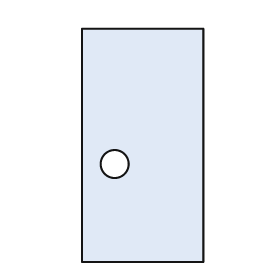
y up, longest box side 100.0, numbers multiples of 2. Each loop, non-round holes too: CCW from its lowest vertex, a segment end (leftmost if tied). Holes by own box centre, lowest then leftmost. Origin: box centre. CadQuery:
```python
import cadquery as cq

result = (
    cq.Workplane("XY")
    .moveTo(-26.0, -50.0)
    .lineTo(26.0, -50.0)
    .lineTo(26.0, 50.0)
    .lineTo(-26.0, 50.0)
    .close()
    .moveTo(-12.0, -8.0)
    .circle(6.0)
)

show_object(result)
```